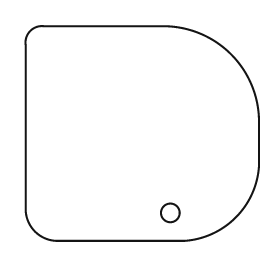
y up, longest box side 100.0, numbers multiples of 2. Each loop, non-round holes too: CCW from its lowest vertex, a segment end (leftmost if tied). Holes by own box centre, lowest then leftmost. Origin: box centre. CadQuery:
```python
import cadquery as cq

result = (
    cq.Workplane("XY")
    .moveTo(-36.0, -46.0)
    .lineTo(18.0, -46.0)
    .threePointArc((40.0, -36.0), (50.0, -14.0))
    .lineTo(50.0, 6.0)
    .threePointArc((38.0, 34.0), (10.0, 46.0))
    .lineTo(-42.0, 46.0)
    .threePointArc((-48.0, 44.0), (-50.0, 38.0))
    .lineTo(-50.0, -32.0)
    .threePointArc((-46.0, -42.0), (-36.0, -46.0))
    .close()
    .moveTo(12.0, -34.0)
    .circle(4.0)
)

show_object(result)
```